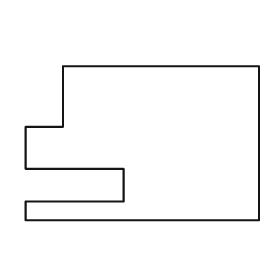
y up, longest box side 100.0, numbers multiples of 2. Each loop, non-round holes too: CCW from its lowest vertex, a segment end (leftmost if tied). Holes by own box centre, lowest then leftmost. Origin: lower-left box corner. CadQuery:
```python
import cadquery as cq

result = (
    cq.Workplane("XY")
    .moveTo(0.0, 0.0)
    .lineTo(100.0, 0.0)
    .lineTo(100.0, 66.0)
    .lineTo(16.0, 66.0)
    .lineTo(16.0, 40.0)
    .lineTo(0.0, 40.0)
    .lineTo(0.0, 22.0)
    .lineTo(42.0, 22.0)
    .lineTo(42.0, 8.0)
    .lineTo(0.0, 8.0)
    .close()
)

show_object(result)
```